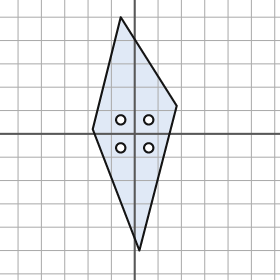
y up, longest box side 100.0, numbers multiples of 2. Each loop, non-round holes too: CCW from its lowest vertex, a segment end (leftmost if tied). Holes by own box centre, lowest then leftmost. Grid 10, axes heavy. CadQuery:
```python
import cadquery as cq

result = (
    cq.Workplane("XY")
    .moveTo(2.0, -50.0)
    .lineTo(18.0, 12.0)
    .lineTo(-6.0, 50.0)
    .lineTo(-18.0, 2.0)
    .close()
    .moveTo(-6.0, -6.0)
    .circle(2.0)
    .moveTo(6.0, -6.0)
    .circle(2.0)
    .moveTo(-6.0, 6.0)
    .circle(2.0)
    .moveTo(6.0, 6.0)
    .circle(2.0)
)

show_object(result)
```